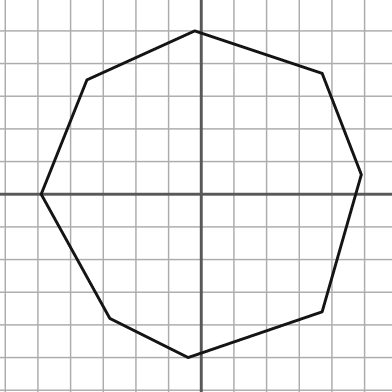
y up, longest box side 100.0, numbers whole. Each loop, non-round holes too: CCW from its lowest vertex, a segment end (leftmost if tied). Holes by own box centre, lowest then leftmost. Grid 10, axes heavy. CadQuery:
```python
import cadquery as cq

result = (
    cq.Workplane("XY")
    .moveTo(-4.0, -50.0)
    .lineTo(37.0, -36.0)
    .lineTo(49.0, 6.0)
    .lineTo(37.0, 37.0)
    .lineTo(-2.0, 50.0)
    .lineTo(-35.0, 35.0)
    .lineTo(-49.0, 0.0)
    .lineTo(-28.0, -38.0)
    .close()
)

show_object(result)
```